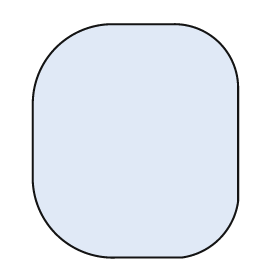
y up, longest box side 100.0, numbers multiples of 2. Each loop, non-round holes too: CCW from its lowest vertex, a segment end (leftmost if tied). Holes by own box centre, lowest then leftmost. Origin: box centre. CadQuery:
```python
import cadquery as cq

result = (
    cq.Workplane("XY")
    .moveTo(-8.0, -50.0)
    .lineTo(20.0, -50.0)
    .threePointArc((36.0, -42.0), (44.0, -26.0))
    .lineTo(44.0, 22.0)
    .threePointArc((36.0, 42.0), (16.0, 50.0))
    .lineTo(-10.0, 50.0)
    .threePointArc((-34.0, 40.0), (-44.0, 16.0))
    .lineTo(-44.0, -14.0)
    .threePointArc((-34.0, -40.0), (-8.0, -50.0))
    .close()
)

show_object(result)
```